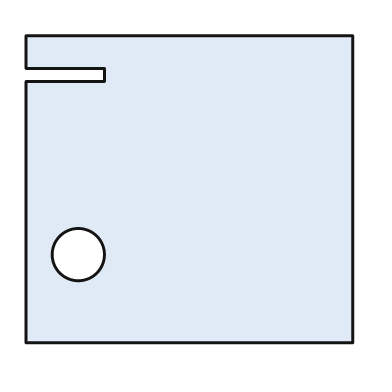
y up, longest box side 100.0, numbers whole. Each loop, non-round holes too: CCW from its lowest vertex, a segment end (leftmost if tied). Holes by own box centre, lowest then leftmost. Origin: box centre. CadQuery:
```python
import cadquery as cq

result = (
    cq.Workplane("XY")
    .moveTo(-50.0, -47.0)
    .lineTo(50.0, -47.0)
    .lineTo(50.0, 47.0)
    .lineTo(-50.0, 47.0)
    .lineTo(-50.0, 37.0)
    .lineTo(-26.0, 37.0)
    .lineTo(-26.0, 33.0)
    .lineTo(-50.0, 33.0)
    .close()
    .moveTo(-34.0, -20.0)
    .circle(8.0)
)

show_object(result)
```